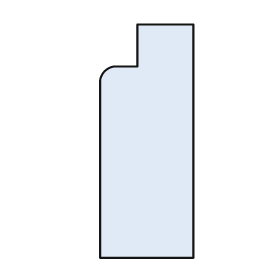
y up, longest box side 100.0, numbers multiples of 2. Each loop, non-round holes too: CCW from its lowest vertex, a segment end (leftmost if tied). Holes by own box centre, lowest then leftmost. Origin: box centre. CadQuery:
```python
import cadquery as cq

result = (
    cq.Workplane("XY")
    .moveTo(-20.0, -50.0)
    .lineTo(20.0, -50.0)
    .lineTo(20.0, 50.0)
    .lineTo(-4.0, 50.0)
    .lineTo(-4.0, 32.0)
    .lineTo(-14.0, 32.0)
    .threePointArc((-18.0, 30.0), (-20.0, 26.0))
    .close()
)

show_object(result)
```